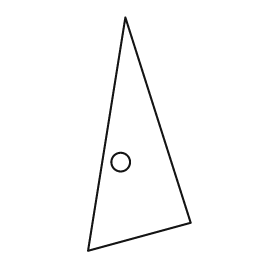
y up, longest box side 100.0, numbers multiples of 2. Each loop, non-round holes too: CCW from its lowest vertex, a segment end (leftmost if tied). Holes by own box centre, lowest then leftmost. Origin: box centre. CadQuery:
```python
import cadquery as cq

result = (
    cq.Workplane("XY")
    .moveTo(-22.0, -50.0)
    .lineTo(22.0, -38.0)
    .lineTo(-6.0, 50.0)
    .close()
    .moveTo(-8.0, -12.0)
    .circle(4.0)
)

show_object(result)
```